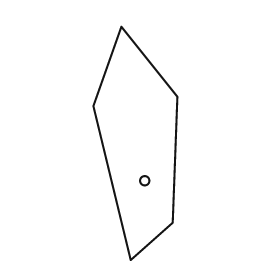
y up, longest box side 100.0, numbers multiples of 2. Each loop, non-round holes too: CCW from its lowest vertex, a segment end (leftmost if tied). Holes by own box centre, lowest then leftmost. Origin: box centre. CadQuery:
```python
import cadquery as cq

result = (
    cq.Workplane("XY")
    .moveTo(-2.0, -50.0)
    .lineTo(16.0, -34.0)
    .lineTo(18.0, 20.0)
    .lineTo(-6.0, 50.0)
    .lineTo(-18.0, 16.0)
    .close()
    .moveTo(4.0, -16.0)
    .circle(2.0)
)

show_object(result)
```